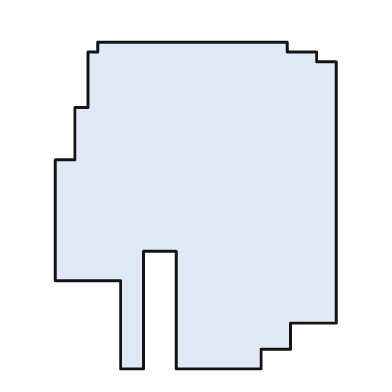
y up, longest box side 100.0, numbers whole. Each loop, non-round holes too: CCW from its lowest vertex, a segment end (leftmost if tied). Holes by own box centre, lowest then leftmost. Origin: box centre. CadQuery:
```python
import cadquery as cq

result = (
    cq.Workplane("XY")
    .moveTo(-23.0, -50.0)
    .lineTo(-16.0, -50.0)
    .lineTo(-16.0, -14.0)
    .lineTo(-6.0, -14.0)
    .lineTo(-6.0, -50.0)
    .lineTo(20.0, -50.0)
    .lineTo(20.0, -44.0)
    .lineTo(29.0, -44.0)
    .lineTo(29.0, -36.0)
    .lineTo(43.0, -36.0)
    .lineTo(43.0, 44.0)
    .lineTo(37.0, 44.0)
    .lineTo(37.0, 47.0)
    .lineTo(28.0, 47.0)
    .lineTo(28.0, 50.0)
    .lineTo(-30.0, 50.0)
    .lineTo(-30.0, 47.0)
    .lineTo(-33.0, 47.0)
    .lineTo(-33.0, 30.0)
    .lineTo(-37.0, 30.0)
    .lineTo(-37.0, 14.0)
    .lineTo(-43.0, 14.0)
    .lineTo(-43.0, -23.0)
    .lineTo(-23.0, -23.0)
    .close()
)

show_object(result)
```